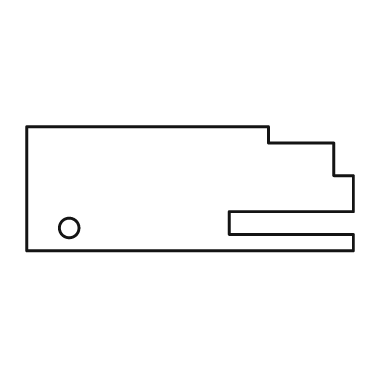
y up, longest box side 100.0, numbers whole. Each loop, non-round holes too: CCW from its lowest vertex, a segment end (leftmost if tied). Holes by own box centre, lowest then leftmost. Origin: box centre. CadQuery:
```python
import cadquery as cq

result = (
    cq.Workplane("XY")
    .moveTo(-50.0, -19.0)
    .lineTo(50.0, -19.0)
    .lineTo(50.0, -14.0)
    .lineTo(12.0, -14.0)
    .lineTo(12.0, -7.0)
    .lineTo(50.0, -7.0)
    .lineTo(50.0, 4.0)
    .lineTo(44.0, 4.0)
    .lineTo(44.0, 14.0)
    .lineTo(24.0, 14.0)
    .lineTo(24.0, 19.0)
    .lineTo(-50.0, 19.0)
    .close()
    .moveTo(-37.0, -12.0)
    .circle(3.0)
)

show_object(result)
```